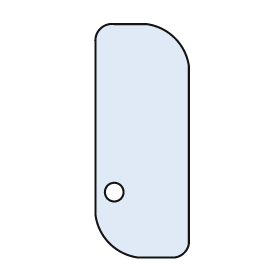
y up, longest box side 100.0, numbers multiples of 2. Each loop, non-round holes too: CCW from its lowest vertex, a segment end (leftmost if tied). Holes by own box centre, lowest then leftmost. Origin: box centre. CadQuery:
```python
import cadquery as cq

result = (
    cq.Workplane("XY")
    .moveTo(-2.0, -50.0)
    .lineTo(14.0, -50.0)
    .threePointArc((18.0, -48.0), (20.0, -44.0))
    .lineTo(20.0, 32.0)
    .threePointArc((14.0, 44.0), (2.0, 50.0))
    .lineTo(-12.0, 50.0)
    .threePointArc((-18.0, 48.0), (-20.0, 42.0))
    .lineTo(-20.0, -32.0)
    .threePointArc((-14.0, -44.0), (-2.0, -50.0))
    .close()
    .moveTo(-12.0, -22.0)
    .circle(4.0)
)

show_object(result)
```